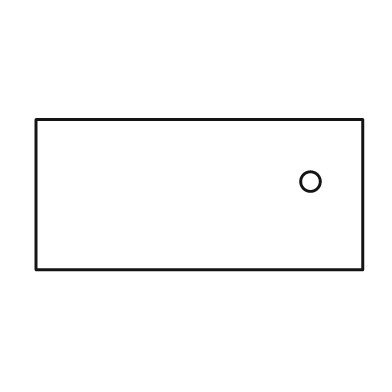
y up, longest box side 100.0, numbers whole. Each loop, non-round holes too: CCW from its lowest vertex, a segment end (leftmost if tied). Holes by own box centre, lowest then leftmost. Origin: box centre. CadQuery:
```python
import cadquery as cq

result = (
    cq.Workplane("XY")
    .moveTo(-50.0, -23.0)
    .lineTo(50.0, -23.0)
    .lineTo(50.0, 23.0)
    .lineTo(-50.0, 23.0)
    .close()
    .moveTo(34.0, 4.0)
    .circle(3.0)
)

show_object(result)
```